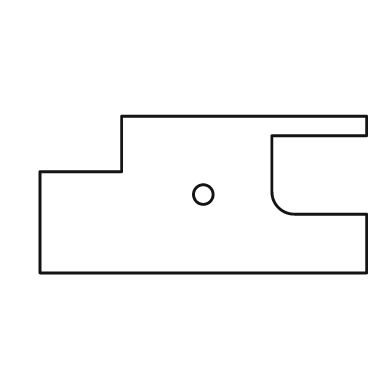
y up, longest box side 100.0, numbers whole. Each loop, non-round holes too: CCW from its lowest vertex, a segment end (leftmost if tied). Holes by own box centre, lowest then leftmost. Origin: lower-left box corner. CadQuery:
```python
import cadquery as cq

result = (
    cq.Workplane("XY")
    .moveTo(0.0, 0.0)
    .lineTo(100.0, 0.0)
    .lineTo(100.0, 18.0)
    .lineTo(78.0, 18.0)
    .threePointArc((73.0, 20.0), (71.0, 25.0))
    .lineTo(71.0, 42.0)
    .lineTo(100.0, 42.0)
    .lineTo(100.0, 48.0)
    .lineTo(25.0, 48.0)
    .lineTo(25.0, 31.0)
    .lineTo(0.0, 31.0)
    .close()
    .moveTo(50.0, 24.0)
    .circle(3.0)
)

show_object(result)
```